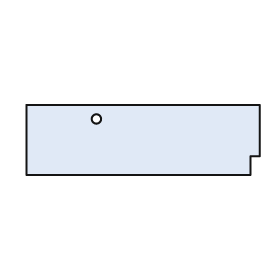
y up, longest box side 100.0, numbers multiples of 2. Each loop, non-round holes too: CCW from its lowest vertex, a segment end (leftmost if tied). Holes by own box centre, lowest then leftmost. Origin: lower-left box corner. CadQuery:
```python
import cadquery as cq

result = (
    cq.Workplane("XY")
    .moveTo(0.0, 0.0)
    .lineTo(96.0, 0.0)
    .lineTo(96.0, 8.0)
    .lineTo(100.0, 8.0)
    .lineTo(100.0, 30.0)
    .lineTo(0.0, 30.0)
    .close()
    .moveTo(30.0, 24.0)
    .circle(2.0)
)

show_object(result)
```